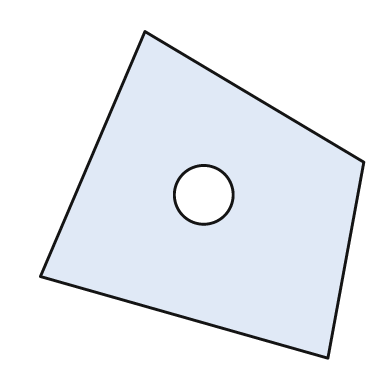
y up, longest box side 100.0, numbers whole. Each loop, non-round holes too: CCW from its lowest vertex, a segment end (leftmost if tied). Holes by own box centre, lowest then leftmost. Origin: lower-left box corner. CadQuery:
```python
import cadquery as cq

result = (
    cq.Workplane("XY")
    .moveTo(88.0, 0.0)
    .lineTo(99.0, 60.0)
    .lineTo(32.0, 100.0)
    .lineTo(0.0, 25.0)
    .close()
    .moveTo(50.0, 50.0)
    .circle(9.0)
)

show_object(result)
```